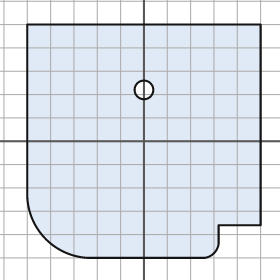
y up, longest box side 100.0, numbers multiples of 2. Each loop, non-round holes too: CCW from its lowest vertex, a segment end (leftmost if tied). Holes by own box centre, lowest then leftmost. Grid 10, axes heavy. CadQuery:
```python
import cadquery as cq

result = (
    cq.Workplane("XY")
    .moveTo(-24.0, -50.0)
    .lineTo(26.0, -50.0)
    .threePointArc((30.0, -48.0), (32.0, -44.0))
    .lineTo(32.0, -36.0)
    .lineTo(50.0, -36.0)
    .lineTo(50.0, 50.0)
    .lineTo(-50.0, 50.0)
    .lineTo(-50.0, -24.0)
    .threePointArc((-42.0, -42.0), (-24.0, -50.0))
    .close()
    .moveTo(0.0, 22.0)
    .circle(4.0)
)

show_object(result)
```